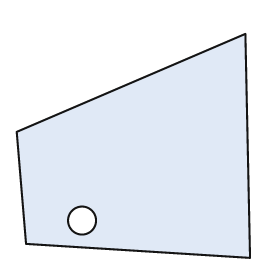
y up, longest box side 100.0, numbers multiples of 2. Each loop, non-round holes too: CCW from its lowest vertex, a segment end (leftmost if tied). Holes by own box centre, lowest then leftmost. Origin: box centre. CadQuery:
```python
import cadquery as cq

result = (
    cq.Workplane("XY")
    .moveTo(50.0, -48.0)
    .lineTo(48.0, 48.0)
    .lineTo(-50.0, 6.0)
    .lineTo(-46.0, -42.0)
    .close()
    .moveTo(-22.0, -32.0)
    .circle(6.0)
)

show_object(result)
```